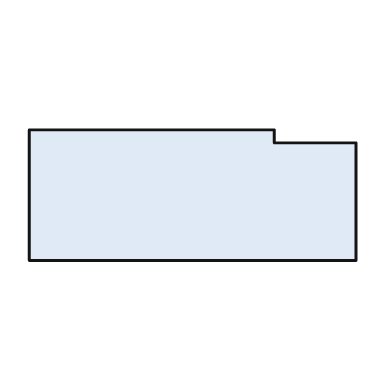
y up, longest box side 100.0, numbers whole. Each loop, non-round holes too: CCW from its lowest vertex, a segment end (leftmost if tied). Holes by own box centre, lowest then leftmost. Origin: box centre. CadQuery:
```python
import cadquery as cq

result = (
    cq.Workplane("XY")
    .moveTo(-50.0, -20.0)
    .lineTo(50.0, -20.0)
    .lineTo(50.0, 16.0)
    .lineTo(25.0, 16.0)
    .lineTo(25.0, 20.0)
    .lineTo(-50.0, 20.0)
    .close()
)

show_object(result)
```